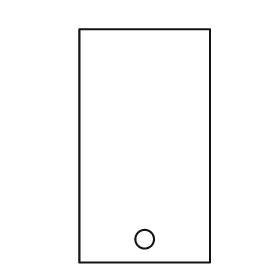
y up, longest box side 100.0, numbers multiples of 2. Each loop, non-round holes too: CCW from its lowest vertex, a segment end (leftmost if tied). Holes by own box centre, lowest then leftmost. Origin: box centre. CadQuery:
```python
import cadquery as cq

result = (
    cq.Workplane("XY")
    .moveTo(-28.0, -50.0)
    .lineTo(28.0, -50.0)
    .lineTo(28.0, 50.0)
    .lineTo(-28.0, 50.0)
    .close()
    .moveTo(0.0, -40.0)
    .circle(4.0)
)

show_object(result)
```